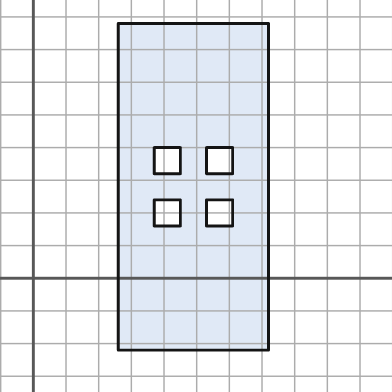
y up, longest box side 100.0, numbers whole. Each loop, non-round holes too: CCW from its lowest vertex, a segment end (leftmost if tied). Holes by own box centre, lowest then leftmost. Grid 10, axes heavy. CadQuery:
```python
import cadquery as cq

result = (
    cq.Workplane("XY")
    .moveTo(26.0, -22.0)
    .lineTo(72.0, -22.0)
    .lineTo(72.0, 78.0)
    .lineTo(26.0, 78.0)
    .close()
    .moveTo(37.0, 16.0)
    .lineTo(45.0, 16.0)
    .lineTo(45.0, 24.0)
    .lineTo(37.0, 24.0)
    .close()
    .moveTo(53.0, 16.0)
    .lineTo(61.0, 16.0)
    .lineTo(61.0, 24.0)
    .lineTo(53.0, 24.0)
    .close()
    .moveTo(37.0, 32.0)
    .lineTo(45.0, 32.0)
    .lineTo(45.0, 40.0)
    .lineTo(37.0, 40.0)
    .close()
    .moveTo(53.0, 32.0)
    .lineTo(61.0, 32.0)
    .lineTo(61.0, 40.0)
    .lineTo(53.0, 40.0)
    .close()
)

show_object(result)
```